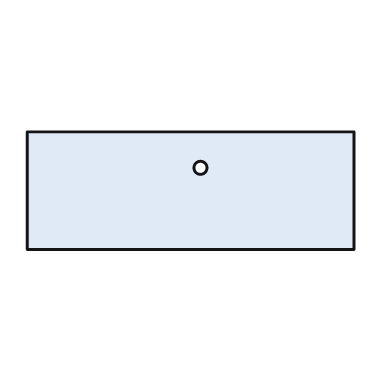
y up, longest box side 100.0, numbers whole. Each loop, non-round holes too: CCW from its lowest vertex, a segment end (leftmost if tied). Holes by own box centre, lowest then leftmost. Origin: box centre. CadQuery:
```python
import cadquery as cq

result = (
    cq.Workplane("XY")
    .moveTo(-50.0, -18.0)
    .lineTo(50.0, -18.0)
    .lineTo(50.0, 18.0)
    .lineTo(-50.0, 18.0)
    .close()
    .moveTo(3.0, 7.0)
    .circle(2.0)
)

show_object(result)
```